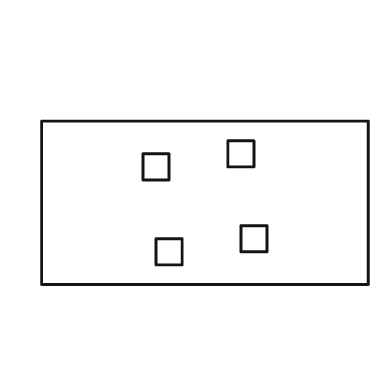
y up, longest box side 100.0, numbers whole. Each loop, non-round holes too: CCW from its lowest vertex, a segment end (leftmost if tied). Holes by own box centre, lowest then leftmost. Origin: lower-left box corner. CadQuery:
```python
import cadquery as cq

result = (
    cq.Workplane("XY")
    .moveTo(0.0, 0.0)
    .lineTo(100.0, 0.0)
    .lineTo(100.0, 50.0)
    .lineTo(0.0, 50.0)
    .close()
    .moveTo(35.0, 6.0)
    .lineTo(43.0, 6.0)
    .lineTo(43.0, 14.0)
    .lineTo(35.0, 14.0)
    .close()
    .moveTo(61.0, 10.0)
    .lineTo(69.0, 10.0)
    .lineTo(69.0, 18.0)
    .lineTo(61.0, 18.0)
    .close()
    .moveTo(31.0, 32.0)
    .lineTo(39.0, 32.0)
    .lineTo(39.0, 40.0)
    .lineTo(31.0, 40.0)
    .close()
    .moveTo(57.0, 36.0)
    .lineTo(65.0, 36.0)
    .lineTo(65.0, 44.0)
    .lineTo(57.0, 44.0)
    .close()
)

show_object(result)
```